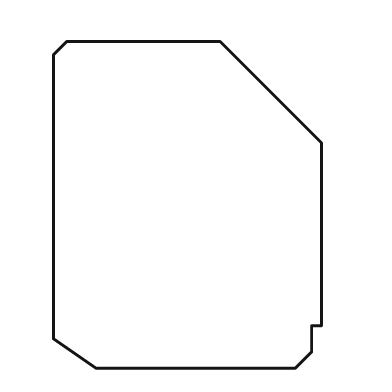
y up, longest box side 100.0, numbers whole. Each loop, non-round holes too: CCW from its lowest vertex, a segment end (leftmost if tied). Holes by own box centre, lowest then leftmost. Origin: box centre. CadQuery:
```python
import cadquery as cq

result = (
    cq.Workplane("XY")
    .moveTo(-28.0, -50.0)
    .lineTo(33.0, -50.0)
    .lineTo(38.0, -45.0)
    .lineTo(38.0, -37.0)
    .lineTo(41.0, -37.0)
    .lineTo(41.0, 19.0)
    .lineTo(10.0, 50.0)
    .lineTo(-37.0, 50.0)
    .lineTo(-41.0, 46.0)
    .lineTo(-41.0, -41.0)
    .close()
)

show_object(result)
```